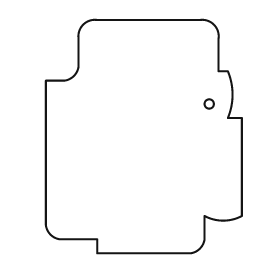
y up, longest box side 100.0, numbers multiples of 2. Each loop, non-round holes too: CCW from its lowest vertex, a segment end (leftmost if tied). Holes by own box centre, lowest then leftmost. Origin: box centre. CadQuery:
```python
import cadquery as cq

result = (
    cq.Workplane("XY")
    .moveTo(-20.0, -50.0)
    .lineTo(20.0, -50.0)
    .threePointArc((24.0, -48.0), (26.0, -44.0))
    .lineTo(26.0, -34.0)
    .threePointArc((34.0, -36.0), (42.0, -34.0))
    .lineTo(42.0, 8.0)
    .lineTo(36.0, 8.0)
    .threePointArc((38.0, 18.0), (36.0, 28.0))
    .lineTo(32.0, 28.0)
    .lineTo(32.0, 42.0)
    .threePointArc((30.0, 48.0), (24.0, 50.0))
    .lineTo(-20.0, 50.0)
    .threePointArc((-26.0, 48.0), (-28.0, 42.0))
    .lineTo(-28.0, 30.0)
    .threePointArc((-30.0, 26.0), (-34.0, 24.0))
    .lineTo(-42.0, 24.0)
    .lineTo(-42.0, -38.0)
    .threePointArc((-40.0, -42.0), (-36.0, -44.0))
    .lineTo(-20.0, -44.0)
    .close()
    .moveTo(28.0, 14.0)
    .circle(2.0)
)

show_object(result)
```